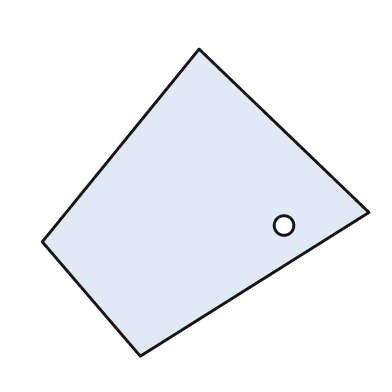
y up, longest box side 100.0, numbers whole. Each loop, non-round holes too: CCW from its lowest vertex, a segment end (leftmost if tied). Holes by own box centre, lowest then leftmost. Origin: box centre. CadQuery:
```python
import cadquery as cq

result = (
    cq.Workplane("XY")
    .moveTo(-20.0, -47.0)
    .lineTo(50.0, -3.0)
    .lineTo(-2.0, 47.0)
    .lineTo(-50.0, -12.0)
    .close()
    .moveTo(24.0, -7.0)
    .circle(3.0)
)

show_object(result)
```